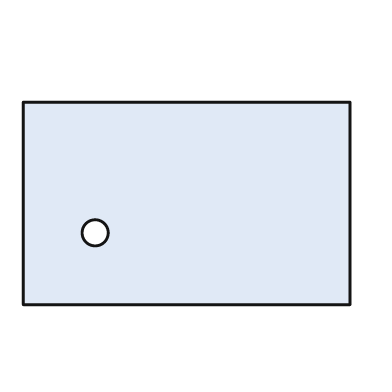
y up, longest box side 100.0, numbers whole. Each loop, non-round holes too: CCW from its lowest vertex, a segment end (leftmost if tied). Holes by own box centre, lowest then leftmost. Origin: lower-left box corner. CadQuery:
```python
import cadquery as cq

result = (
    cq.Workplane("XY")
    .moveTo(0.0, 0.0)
    .lineTo(100.0, 0.0)
    .lineTo(100.0, 62.0)
    .lineTo(0.0, 62.0)
    .close()
    .moveTo(22.0, 22.0)
    .circle(4.0)
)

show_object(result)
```